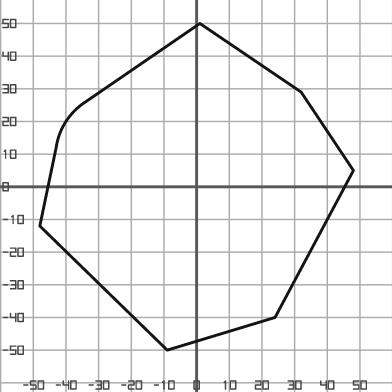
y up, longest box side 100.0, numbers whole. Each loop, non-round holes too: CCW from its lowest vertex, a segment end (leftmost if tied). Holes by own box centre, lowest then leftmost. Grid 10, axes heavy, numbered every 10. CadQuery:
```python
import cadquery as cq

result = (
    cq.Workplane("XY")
    .moveTo(-9.0, -50.0)
    .lineTo(24.0, -40.0)
    .lineTo(48.0, 5.0)
    .lineTo(32.0, 29.0)
    .lineTo(1.0, 50.0)
    .lineTo(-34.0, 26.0)
    .threePointArc((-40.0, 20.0), (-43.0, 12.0))
    .lineTo(-48.0, -12.0)
    .close()
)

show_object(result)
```